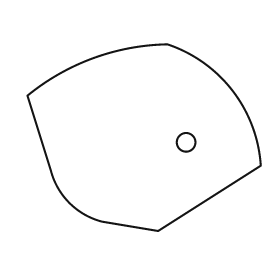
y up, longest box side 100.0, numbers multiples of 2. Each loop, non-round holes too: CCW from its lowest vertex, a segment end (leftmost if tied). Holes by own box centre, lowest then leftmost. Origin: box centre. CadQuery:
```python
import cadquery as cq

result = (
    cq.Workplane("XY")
    .moveTo(6.0, -40.0)
    .lineTo(50.0, -12.0)
    .threePointArc((38.0, 20.0), (10.0, 40.0))
    .threePointArc((-22.0, 34.0), (-50.0, 18.0))
    .lineTo(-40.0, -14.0)
    .threePointArc((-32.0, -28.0), (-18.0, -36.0))
    .close()
    .moveTo(18.0, -2.0)
    .circle(4.0)
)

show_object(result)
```